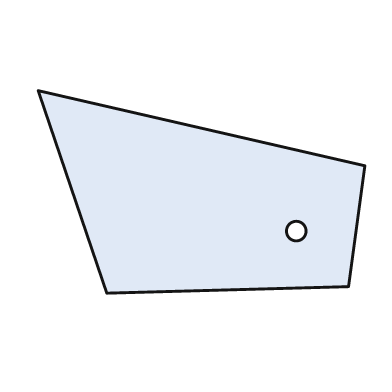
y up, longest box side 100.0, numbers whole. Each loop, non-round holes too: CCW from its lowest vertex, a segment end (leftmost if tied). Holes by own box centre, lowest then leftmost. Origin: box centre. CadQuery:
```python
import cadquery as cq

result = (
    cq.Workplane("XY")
    .moveTo(-29.0, -31.0)
    .lineTo(45.0, -29.0)
    .lineTo(50.0, 8.0)
    .lineTo(-50.0, 31.0)
    .close()
    .moveTo(29.0, -12.0)
    .circle(3.0)
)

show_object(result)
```